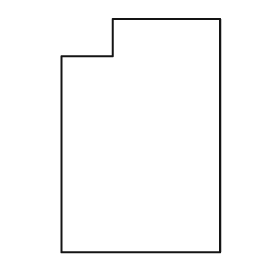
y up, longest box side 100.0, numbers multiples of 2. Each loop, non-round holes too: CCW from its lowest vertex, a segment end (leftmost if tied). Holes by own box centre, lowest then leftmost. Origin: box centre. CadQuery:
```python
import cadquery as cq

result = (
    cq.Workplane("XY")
    .moveTo(-34.0, -50.0)
    .lineTo(34.0, -50.0)
    .lineTo(34.0, 50.0)
    .lineTo(-12.0, 50.0)
    .lineTo(-12.0, 34.0)
    .lineTo(-34.0, 34.0)
    .close()
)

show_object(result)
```